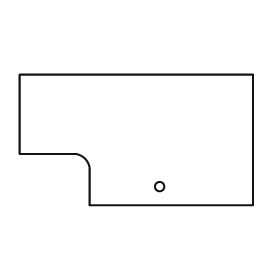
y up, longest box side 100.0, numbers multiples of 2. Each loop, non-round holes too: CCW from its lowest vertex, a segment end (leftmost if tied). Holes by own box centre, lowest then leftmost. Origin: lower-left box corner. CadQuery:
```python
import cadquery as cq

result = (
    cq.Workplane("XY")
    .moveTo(30.0, 0.0)
    .lineTo(100.0, 0.0)
    .lineTo(100.0, 56.0)
    .lineTo(0.0, 56.0)
    .lineTo(0.0, 22.0)
    .lineTo(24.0, 22.0)
    .threePointArc((28.0, 20.0), (30.0, 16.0))
    .close()
    .moveTo(60.0, 8.0)
    .circle(2.0)
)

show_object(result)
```